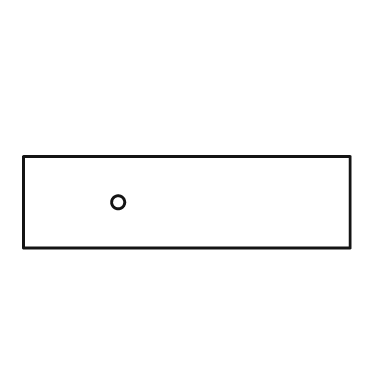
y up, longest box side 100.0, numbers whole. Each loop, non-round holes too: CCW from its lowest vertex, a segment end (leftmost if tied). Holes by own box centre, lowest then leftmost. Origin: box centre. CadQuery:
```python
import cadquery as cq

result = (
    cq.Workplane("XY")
    .moveTo(-50.0, -14.0)
    .lineTo(50.0, -14.0)
    .lineTo(50.0, 14.0)
    .lineTo(-50.0, 14.0)
    .close()
    .moveTo(-21.0, 0.0)
    .circle(2.0)
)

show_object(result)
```